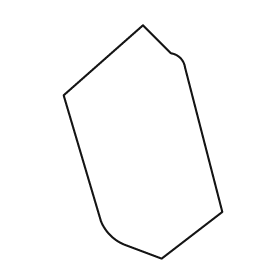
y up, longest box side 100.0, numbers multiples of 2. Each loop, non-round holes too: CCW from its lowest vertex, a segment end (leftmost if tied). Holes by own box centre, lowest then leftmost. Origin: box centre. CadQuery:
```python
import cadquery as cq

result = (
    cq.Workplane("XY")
    .moveTo(8.0, -50.0)
    .lineTo(34.0, -30.0)
    .lineTo(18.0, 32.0)
    .threePointArc((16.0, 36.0), (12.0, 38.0))
    .lineTo(0.0, 50.0)
    .lineTo(-34.0, 20.0)
    .lineTo(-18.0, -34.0)
    .threePointArc((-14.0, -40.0), (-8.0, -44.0))
    .close()
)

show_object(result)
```